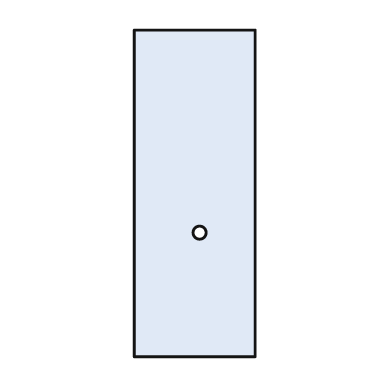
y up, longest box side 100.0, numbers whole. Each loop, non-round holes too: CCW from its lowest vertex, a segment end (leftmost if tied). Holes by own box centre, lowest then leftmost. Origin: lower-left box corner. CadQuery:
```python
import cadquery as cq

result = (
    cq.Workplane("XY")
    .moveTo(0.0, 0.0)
    .lineTo(37.0, 0.0)
    .lineTo(37.0, 100.0)
    .lineTo(0.0, 100.0)
    .close()
    .moveTo(20.0, 38.0)
    .circle(2.0)
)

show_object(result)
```